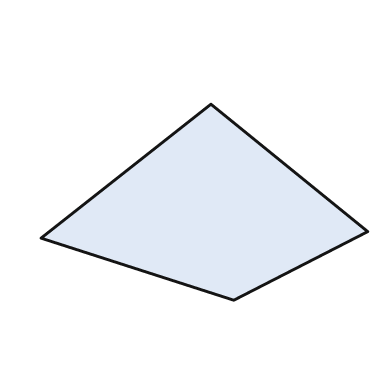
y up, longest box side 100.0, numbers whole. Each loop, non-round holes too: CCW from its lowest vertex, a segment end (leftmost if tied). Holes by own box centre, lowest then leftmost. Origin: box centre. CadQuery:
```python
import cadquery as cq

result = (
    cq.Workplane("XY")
    .moveTo(9.0, -30.0)
    .lineTo(50.0, -9.0)
    .lineTo(2.0, 30.0)
    .lineTo(-50.0, -11.0)
    .close()
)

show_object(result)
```